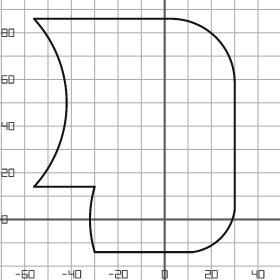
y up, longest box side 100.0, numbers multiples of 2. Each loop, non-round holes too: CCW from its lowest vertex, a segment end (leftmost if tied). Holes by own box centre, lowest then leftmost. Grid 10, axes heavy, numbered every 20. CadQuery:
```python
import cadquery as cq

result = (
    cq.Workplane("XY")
    .moveTo(-30.0, -14.0)
    .lineTo(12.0, -14.0)
    .threePointArc((24.0, -8.0), (30.0, 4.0))
    .lineTo(30.0, 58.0)
    .threePointArc((22.0, 78.0), (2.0, 86.0))
    .lineTo(-56.0, 86.0)
    .threePointArc((-42.0, 50.0), (-56.0, 14.0))
    .lineTo(-30.0, 14.0)
    .threePointArc((-32.0, 0.0), (-30.0, -14.0))
    .close()
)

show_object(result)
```